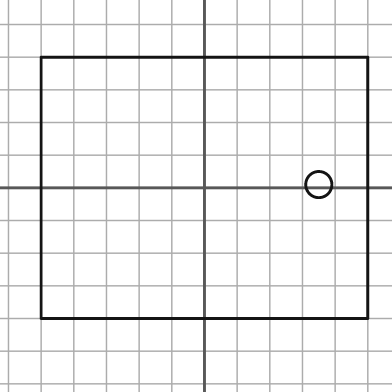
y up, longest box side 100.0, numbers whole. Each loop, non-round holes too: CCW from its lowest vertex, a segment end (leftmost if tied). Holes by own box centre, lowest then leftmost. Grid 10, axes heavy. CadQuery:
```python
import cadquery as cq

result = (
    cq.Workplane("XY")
    .moveTo(-50.0, -40.0)
    .lineTo(50.0, -40.0)
    .lineTo(50.0, 40.0)
    .lineTo(-50.0, 40.0)
    .close()
    .moveTo(35.0, 1.0)
    .circle(4.0)
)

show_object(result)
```